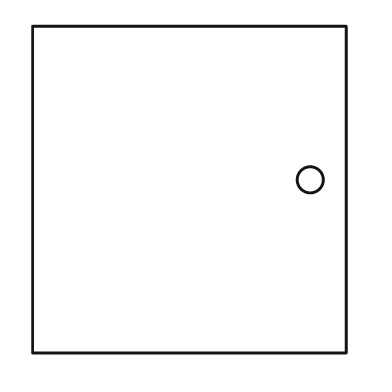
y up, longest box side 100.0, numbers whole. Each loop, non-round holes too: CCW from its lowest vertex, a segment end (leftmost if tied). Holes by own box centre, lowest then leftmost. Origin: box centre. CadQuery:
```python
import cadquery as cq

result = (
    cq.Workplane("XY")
    .moveTo(-48.0, -50.0)
    .lineTo(48.0, -50.0)
    .lineTo(48.0, 50.0)
    .lineTo(-48.0, 50.0)
    .close()
    .moveTo(37.0, 3.0)
    .circle(4.0)
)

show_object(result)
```